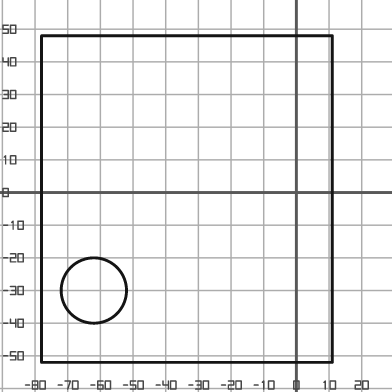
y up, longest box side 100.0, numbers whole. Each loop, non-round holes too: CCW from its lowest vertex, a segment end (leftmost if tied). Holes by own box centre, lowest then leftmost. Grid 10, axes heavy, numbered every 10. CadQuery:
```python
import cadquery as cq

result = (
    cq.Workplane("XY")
    .moveTo(-78.0, -52.0)
    .lineTo(11.0, -52.0)
    .lineTo(11.0, 48.0)
    .lineTo(-78.0, 48.0)
    .close()
    .moveTo(-62.0, -30.0)
    .circle(10.0)
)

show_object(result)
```